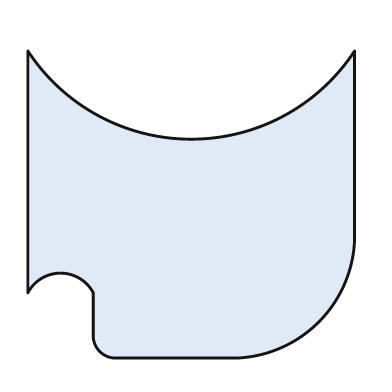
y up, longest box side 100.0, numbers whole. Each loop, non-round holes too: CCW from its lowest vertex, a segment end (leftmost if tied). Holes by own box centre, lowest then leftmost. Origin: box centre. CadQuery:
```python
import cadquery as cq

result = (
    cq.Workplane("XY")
    .moveTo(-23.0, -47.0)
    .lineTo(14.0, -47.0)
    .threePointArc((39.0, -36.0), (50.0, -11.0))
    .lineTo(50.0, 47.0)
    .threePointArc((0.0, 20.0), (-50.0, 47.0))
    .lineTo(-50.0, -27.0)
    .threePointArc((-40.0, -21.0), (-30.0, -27.0))
    .lineTo(-30.0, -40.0)
    .threePointArc((-28.0, -45.0), (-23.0, -47.0))
    .close()
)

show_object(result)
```